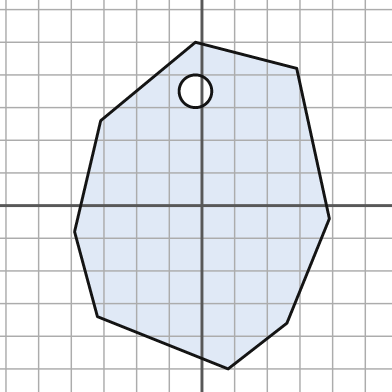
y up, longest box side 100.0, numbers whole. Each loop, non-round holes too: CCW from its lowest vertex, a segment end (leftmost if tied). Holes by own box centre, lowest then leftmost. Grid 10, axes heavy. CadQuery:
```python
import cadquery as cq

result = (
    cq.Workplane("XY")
    .moveTo(8.0, -50.0)
    .lineTo(26.0, -36.0)
    .lineTo(39.0, -4.0)
    .lineTo(29.0, 42.0)
    .lineTo(-2.0, 50.0)
    .lineTo(-31.0, 26.0)
    .lineTo(-39.0, -8.0)
    .lineTo(-32.0, -34.0)
    .close()
    .moveTo(-2.0, 35.0)
    .circle(5.0)
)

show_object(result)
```